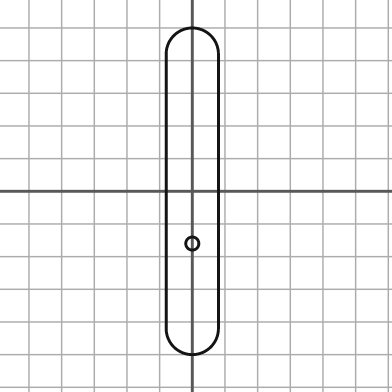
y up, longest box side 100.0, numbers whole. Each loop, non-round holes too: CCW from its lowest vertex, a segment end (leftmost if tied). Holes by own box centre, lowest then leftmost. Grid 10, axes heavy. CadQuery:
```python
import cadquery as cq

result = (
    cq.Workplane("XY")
    .moveTo(-8.0, -42.0)
    .threePointArc((0.0, -50.0), (8.0, -42.0))
    .lineTo(8.0, 42.0)
    .threePointArc((0.0, 50.0), (-8.0, 42.0))
    .close()
    .moveTo(0.0, -16.0)
    .circle(2.0)
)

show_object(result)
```